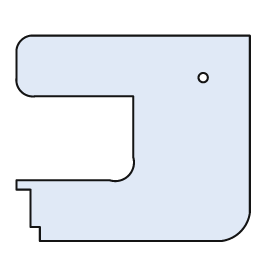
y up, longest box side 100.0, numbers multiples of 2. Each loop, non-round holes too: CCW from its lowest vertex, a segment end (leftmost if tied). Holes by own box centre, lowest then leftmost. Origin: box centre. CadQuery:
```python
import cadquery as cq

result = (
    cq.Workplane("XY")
    .moveTo(-40.0, -44.0)
    .lineTo(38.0, -44.0)
    .threePointArc((46.0, -40.0), (50.0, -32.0))
    .lineTo(50.0, 44.0)
    .lineTo(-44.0, 44.0)
    .threePointArc((-48.0, 42.0), (-50.0, 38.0))
    .lineTo(-50.0, 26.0)
    .threePointArc((-48.0, 20.0), (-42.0, 18.0))
    .lineTo(0.0, 18.0)
    .lineTo(0.0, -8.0)
    .threePointArc((-2.0, -16.0), (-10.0, -18.0))
    .lineTo(-50.0, -18.0)
    .lineTo(-50.0, -22.0)
    .lineTo(-44.0, -22.0)
    .lineTo(-44.0, -38.0)
    .lineTo(-40.0, -38.0)
    .close()
    .moveTo(30.0, 26.0)
    .circle(2.0)
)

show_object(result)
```